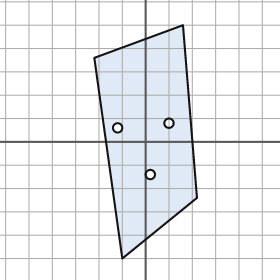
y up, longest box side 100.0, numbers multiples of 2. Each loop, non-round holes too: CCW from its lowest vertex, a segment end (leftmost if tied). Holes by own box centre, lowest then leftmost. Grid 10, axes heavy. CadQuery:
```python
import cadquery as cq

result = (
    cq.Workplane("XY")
    .moveTo(-10.0, -50.0)
    .lineTo(22.0, -24.0)
    .lineTo(16.0, 50.0)
    .lineTo(-22.0, 36.0)
    .close()
    .moveTo(2.0, -14.0)
    .circle(2.0)
    .moveTo(-12.0, 6.0)
    .circle(2.0)
    .moveTo(10.0, 8.0)
    .circle(2.0)
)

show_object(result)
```